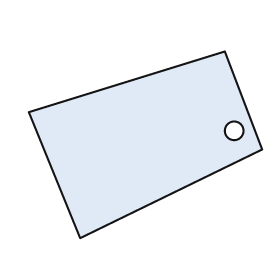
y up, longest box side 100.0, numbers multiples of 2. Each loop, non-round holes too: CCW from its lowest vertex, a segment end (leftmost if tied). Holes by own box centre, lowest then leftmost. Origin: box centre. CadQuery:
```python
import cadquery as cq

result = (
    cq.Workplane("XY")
    .moveTo(-28.0, -40.0)
    .lineTo(50.0, -2.0)
    .lineTo(34.0, 40.0)
    .lineTo(-50.0, 14.0)
    .close()
    .moveTo(38.0, 6.0)
    .circle(4.0)
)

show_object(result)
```